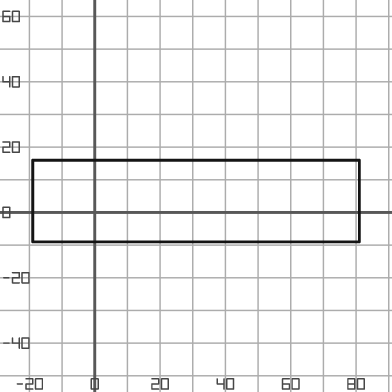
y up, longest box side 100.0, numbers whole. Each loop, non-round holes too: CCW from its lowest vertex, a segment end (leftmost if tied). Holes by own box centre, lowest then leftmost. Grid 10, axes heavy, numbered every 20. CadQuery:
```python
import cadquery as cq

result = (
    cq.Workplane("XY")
    .moveTo(-19.0, -9.0)
    .lineTo(81.0, -9.0)
    .lineTo(81.0, 16.0)
    .lineTo(-19.0, 16.0)
    .close()
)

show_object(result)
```